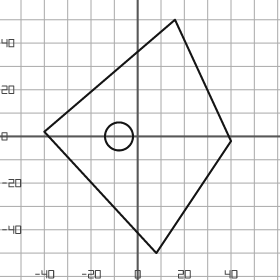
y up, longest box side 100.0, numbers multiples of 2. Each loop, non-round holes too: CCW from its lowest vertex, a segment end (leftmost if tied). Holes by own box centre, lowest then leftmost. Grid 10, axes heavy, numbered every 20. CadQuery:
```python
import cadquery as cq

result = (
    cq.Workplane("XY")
    .moveTo(8.0, -50.0)
    .lineTo(40.0, -2.0)
    .lineTo(16.0, 50.0)
    .lineTo(-40.0, 2.0)
    .close()
    .moveTo(-8.0, 0.0)
    .circle(6.0)
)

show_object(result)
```